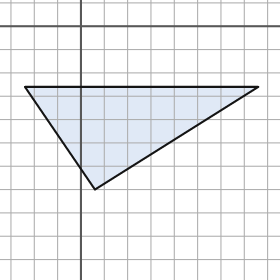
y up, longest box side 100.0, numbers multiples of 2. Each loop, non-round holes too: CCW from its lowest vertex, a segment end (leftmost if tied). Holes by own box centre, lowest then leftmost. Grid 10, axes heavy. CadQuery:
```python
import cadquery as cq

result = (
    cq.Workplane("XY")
    .moveTo(6.0, -70.0)
    .lineTo(76.0, -26.0)
    .lineTo(-24.0, -26.0)
    .close()
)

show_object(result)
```